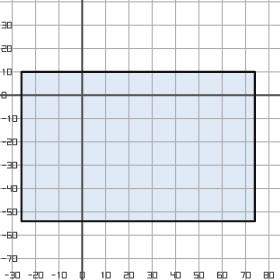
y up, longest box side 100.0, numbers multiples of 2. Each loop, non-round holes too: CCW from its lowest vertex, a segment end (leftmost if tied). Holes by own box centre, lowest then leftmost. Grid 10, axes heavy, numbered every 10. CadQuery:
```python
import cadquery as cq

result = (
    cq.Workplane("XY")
    .moveTo(-26.0, -54.0)
    .lineTo(74.0, -54.0)
    .lineTo(74.0, 10.0)
    .lineTo(-26.0, 10.0)
    .close()
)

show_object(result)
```